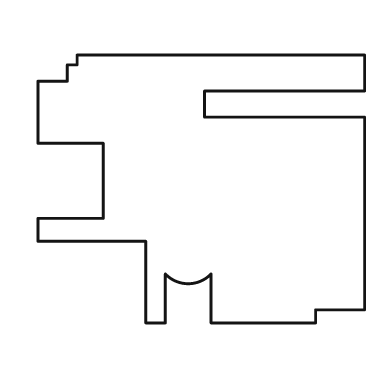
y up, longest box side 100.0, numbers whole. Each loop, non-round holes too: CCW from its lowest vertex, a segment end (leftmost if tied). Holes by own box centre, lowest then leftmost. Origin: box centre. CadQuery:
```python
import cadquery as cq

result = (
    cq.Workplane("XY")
    .moveTo(-17.0, -41.0)
    .lineTo(-11.0, -41.0)
    .lineTo(-11.0, -26.0)
    .threePointArc((-4.0, -29.0), (3.0, -26.0))
    .lineTo(3.0, -41.0)
    .lineTo(35.0, -41.0)
    .lineTo(35.0, -37.0)
    .lineTo(50.0, -37.0)
    .lineTo(50.0, 22.0)
    .lineTo(1.0, 22.0)
    .lineTo(1.0, 30.0)
    .lineTo(50.0, 30.0)
    .lineTo(50.0, 41.0)
    .lineTo(-38.0, 41.0)
    .lineTo(-38.0, 38.0)
    .lineTo(-41.0, 38.0)
    .lineTo(-41.0, 33.0)
    .lineTo(-50.0, 33.0)
    .lineTo(-50.0, 14.0)
    .lineTo(-30.0, 14.0)
    .lineTo(-30.0, -9.0)
    .lineTo(-50.0, -9.0)
    .lineTo(-50.0, -16.0)
    .lineTo(-17.0, -16.0)
    .close()
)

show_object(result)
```